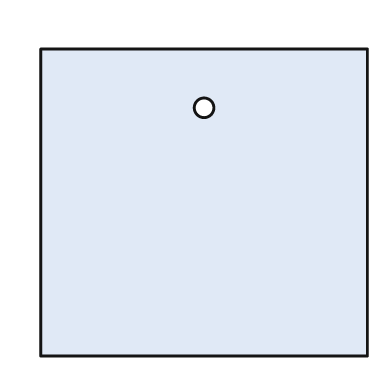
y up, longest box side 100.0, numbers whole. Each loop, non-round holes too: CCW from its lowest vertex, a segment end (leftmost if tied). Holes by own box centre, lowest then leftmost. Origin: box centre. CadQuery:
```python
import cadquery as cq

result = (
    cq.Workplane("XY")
    .moveTo(-50.0, -47.0)
    .lineTo(50.0, -47.0)
    .lineTo(50.0, 47.0)
    .lineTo(-50.0, 47.0)
    .close()
    .moveTo(0.0, 29.0)
    .circle(3.0)
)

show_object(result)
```